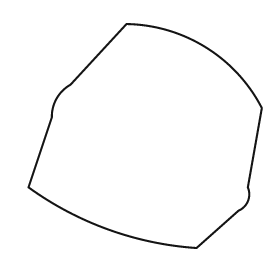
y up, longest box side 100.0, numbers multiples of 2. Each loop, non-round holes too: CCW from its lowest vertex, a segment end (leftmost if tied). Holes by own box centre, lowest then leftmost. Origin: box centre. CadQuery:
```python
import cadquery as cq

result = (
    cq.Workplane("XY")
    .moveTo(22.0, -48.0)
    .lineTo(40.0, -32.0)
    .threePointArc((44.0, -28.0), (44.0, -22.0))
    .lineTo(50.0, 12.0)
    .threePointArc((26.0, 38.0), (-8.0, 48.0))
    .lineTo(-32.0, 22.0)
    .threePointArc((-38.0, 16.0), (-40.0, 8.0))
    .lineTo(-50.0, -22.0)
    .threePointArc((-16.0, -40.0), (22.0, -48.0))
    .close()
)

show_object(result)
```